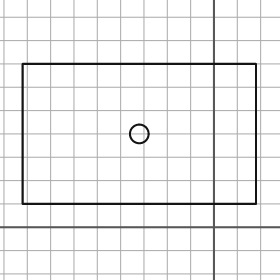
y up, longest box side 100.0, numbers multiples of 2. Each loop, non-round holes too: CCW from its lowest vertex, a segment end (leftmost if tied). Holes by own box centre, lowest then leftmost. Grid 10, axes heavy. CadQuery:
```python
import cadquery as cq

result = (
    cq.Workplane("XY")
    .moveTo(-82.0, 10.0)
    .lineTo(18.0, 10.0)
    .lineTo(18.0, 70.0)
    .lineTo(-82.0, 70.0)
    .close()
    .moveTo(-32.0, 40.0)
    .circle(4.0)
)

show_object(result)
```